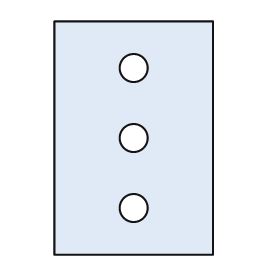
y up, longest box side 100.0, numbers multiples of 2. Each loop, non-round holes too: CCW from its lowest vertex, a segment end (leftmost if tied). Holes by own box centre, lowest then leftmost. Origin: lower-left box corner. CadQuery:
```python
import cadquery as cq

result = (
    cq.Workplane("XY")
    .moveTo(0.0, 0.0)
    .lineTo(68.0, 0.0)
    .lineTo(68.0, 100.0)
    .lineTo(0.0, 100.0)
    .close()
    .moveTo(34.0, 20.0)
    .circle(6.0)
    .moveTo(34.0, 50.0)
    .circle(6.0)
    .moveTo(34.0, 80.0)
    .circle(6.0)
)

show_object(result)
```